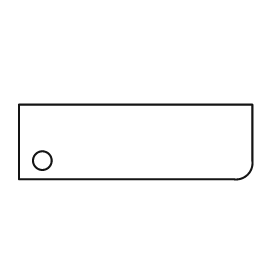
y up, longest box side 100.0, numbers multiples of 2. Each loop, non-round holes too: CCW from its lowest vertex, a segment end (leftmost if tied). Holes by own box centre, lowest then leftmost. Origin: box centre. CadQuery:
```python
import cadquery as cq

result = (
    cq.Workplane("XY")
    .moveTo(-50.0, -16.0)
    .lineTo(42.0, -16.0)
    .threePointArc((48.0, -14.0), (50.0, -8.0))
    .lineTo(50.0, 16.0)
    .lineTo(-50.0, 16.0)
    .close()
    .moveTo(-40.0, -8.0)
    .circle(4.0)
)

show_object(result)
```